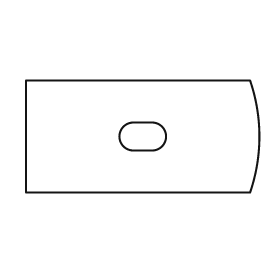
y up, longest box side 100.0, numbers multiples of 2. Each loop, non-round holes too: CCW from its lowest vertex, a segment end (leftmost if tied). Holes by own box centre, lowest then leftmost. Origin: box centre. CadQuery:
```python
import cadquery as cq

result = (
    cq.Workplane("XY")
    .moveTo(-50.0, -24.0)
    .lineTo(46.0, -24.0)
    .threePointArc((50.0, 0.0), (46.0, 24.0))
    .lineTo(-50.0, 24.0)
    .close()
    .moveTo(-4.0, -6.0)
    .lineTo(4.0, -6.0)
    .threePointArc((10.0, 0.0), (4.0, 6.0))
    .lineTo(-4.0, 6.0)
    .threePointArc((-10.0, 0.0), (-4.0, -6.0))
    .close()
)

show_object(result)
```